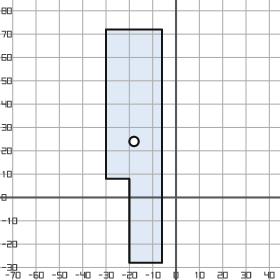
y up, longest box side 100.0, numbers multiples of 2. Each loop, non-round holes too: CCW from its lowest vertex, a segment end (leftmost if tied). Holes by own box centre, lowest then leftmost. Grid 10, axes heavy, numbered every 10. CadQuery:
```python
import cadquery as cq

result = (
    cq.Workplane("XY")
    .moveTo(-20.0, -28.0)
    .lineTo(-6.0, -28.0)
    .lineTo(-6.0, 72.0)
    .lineTo(-30.0, 72.0)
    .lineTo(-30.0, 8.0)
    .lineTo(-20.0, 8.0)
    .close()
    .moveTo(-18.0, 24.0)
    .circle(2.0)
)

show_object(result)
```